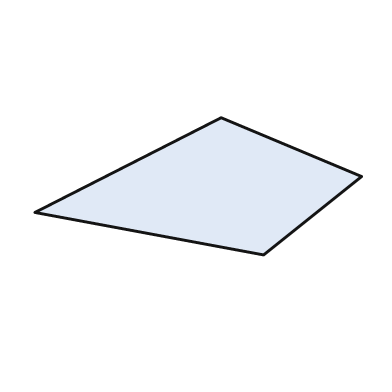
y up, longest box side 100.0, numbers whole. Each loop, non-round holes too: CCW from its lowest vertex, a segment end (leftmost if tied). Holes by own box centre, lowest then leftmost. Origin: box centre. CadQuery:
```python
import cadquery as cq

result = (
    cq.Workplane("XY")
    .moveTo(20.0, -21.0)
    .lineTo(50.0, 3.0)
    .lineTo(7.0, 21.0)
    .lineTo(-50.0, -8.0)
    .close()
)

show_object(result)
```